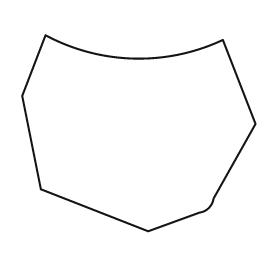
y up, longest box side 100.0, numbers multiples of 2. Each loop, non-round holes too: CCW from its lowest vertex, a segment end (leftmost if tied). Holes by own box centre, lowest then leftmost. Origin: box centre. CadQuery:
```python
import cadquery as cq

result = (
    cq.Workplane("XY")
    .moveTo(4.0, -42.0)
    .lineTo(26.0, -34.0)
    .threePointArc((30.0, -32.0), (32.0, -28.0))
    .lineTo(50.0, 4.0)
    .lineTo(36.0, 40.0)
    .threePointArc((-2.0, 32.0), (-40.0, 42.0))
    .lineTo(-50.0, 16.0)
    .lineTo(-42.0, -24.0)
    .close()
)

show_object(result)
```